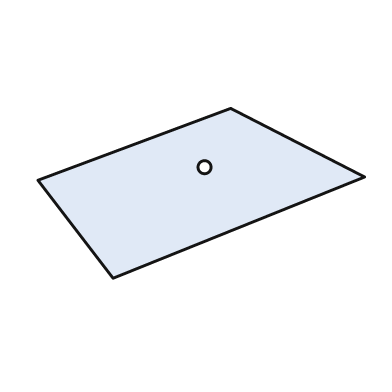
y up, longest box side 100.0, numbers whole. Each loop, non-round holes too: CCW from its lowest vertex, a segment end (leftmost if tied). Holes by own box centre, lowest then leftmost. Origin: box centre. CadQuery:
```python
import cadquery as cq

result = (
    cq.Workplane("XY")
    .moveTo(-27.0, -26.0)
    .lineTo(50.0, 5.0)
    .lineTo(9.0, 26.0)
    .lineTo(-50.0, 4.0)
    .close()
    .moveTo(1.0, 8.0)
    .circle(2.0)
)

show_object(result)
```